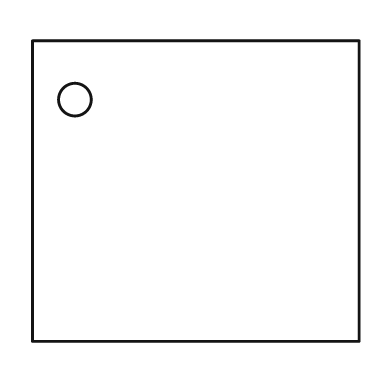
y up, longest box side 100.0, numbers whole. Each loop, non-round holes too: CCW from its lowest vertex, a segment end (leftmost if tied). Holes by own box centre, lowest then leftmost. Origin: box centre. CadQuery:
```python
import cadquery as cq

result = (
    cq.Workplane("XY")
    .moveTo(-50.0, -46.0)
    .lineTo(50.0, -46.0)
    .lineTo(50.0, 46.0)
    .lineTo(-50.0, 46.0)
    .close()
    .moveTo(-37.0, 28.0)
    .circle(5.0)
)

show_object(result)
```